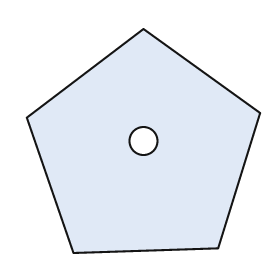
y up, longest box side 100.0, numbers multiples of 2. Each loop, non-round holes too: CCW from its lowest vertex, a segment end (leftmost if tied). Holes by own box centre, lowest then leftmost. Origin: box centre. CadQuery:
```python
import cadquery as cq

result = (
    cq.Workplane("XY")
    .moveTo(-30.0, -48.0)
    .lineTo(32.0, -46.0)
    .lineTo(50.0, 12.0)
    .lineTo(0.0, 48.0)
    .lineTo(-50.0, 10.0)
    .close()
    .moveTo(0.0, 0.0)
    .circle(6.0)
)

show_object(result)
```